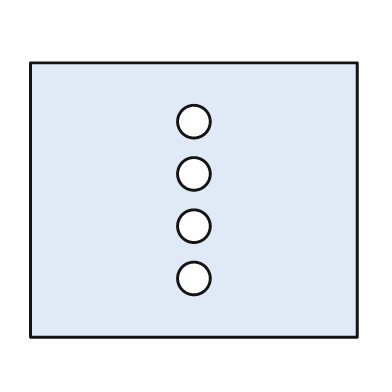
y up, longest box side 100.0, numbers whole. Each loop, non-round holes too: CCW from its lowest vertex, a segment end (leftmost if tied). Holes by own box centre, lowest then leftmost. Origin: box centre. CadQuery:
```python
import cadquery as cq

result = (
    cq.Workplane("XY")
    .moveTo(-50.0, -42.0)
    .lineTo(50.0, -42.0)
    .lineTo(50.0, 42.0)
    .lineTo(-50.0, 42.0)
    .close()
    .moveTo(0.0, -24.0)
    .circle(5.0)
    .moveTo(0.0, -8.0)
    .circle(5.0)
    .moveTo(0.0, 8.0)
    .circle(5.0)
    .moveTo(0.0, 24.0)
    .circle(5.0)
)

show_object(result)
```